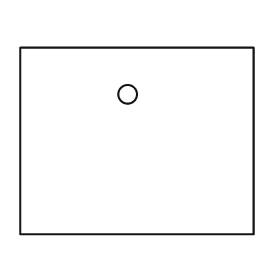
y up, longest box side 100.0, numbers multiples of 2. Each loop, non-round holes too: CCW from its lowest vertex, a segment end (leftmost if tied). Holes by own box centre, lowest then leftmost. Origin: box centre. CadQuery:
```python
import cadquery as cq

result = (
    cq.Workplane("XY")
    .moveTo(-50.0, -40.0)
    .lineTo(50.0, -40.0)
    .lineTo(50.0, 40.0)
    .lineTo(-50.0, 40.0)
    .close()
    .moveTo(-4.0, 20.0)
    .circle(4.0)
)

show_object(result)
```